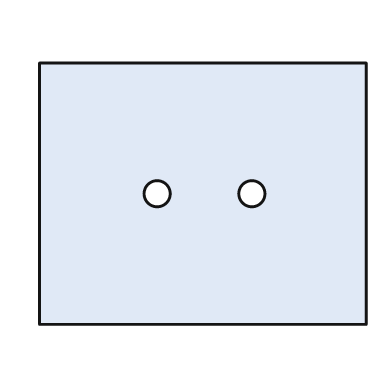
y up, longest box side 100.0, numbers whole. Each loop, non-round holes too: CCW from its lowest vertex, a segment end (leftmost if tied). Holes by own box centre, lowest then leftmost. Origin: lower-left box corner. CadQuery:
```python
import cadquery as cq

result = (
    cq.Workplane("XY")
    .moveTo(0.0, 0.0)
    .lineTo(100.0, 0.0)
    .lineTo(100.0, 80.0)
    .lineTo(0.0, 80.0)
    .close()
    .moveTo(36.0, 40.0)
    .circle(4.0)
    .moveTo(65.0, 40.0)
    .circle(4.0)
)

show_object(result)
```